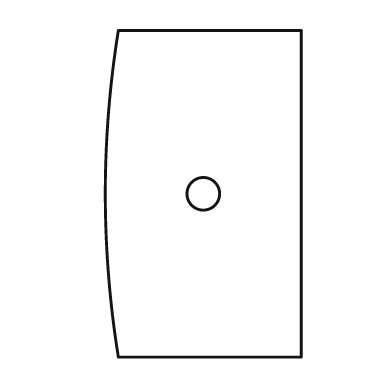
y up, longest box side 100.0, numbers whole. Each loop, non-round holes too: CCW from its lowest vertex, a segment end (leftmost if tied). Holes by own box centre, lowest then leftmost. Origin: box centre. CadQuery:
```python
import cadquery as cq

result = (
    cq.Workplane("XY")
    .moveTo(-26.0, -50.0)
    .lineTo(30.0, -50.0)
    .lineTo(30.0, 50.0)
    .lineTo(-26.0, 50.0)
    .threePointArc((-30.0, 0.0), (-26.0, -50.0))
    .close()
    .moveTo(0.0, 0.0)
    .circle(5.0)
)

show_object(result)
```